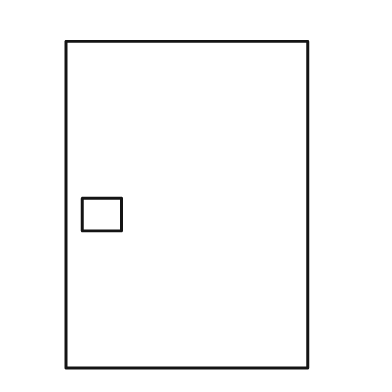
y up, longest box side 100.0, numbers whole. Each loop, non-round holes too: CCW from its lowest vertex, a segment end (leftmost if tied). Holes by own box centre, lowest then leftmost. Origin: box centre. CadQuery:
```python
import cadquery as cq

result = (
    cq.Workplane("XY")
    .moveTo(-37.0, -50.0)
    .lineTo(37.0, -50.0)
    .lineTo(37.0, 50.0)
    .lineTo(-37.0, 50.0)
    .close()
    .moveTo(-32.0, -8.0)
    .lineTo(-20.0, -8.0)
    .lineTo(-20.0, 2.0)
    .lineTo(-32.0, 2.0)
    .close()
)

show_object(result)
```